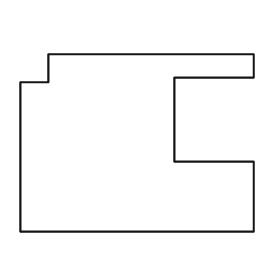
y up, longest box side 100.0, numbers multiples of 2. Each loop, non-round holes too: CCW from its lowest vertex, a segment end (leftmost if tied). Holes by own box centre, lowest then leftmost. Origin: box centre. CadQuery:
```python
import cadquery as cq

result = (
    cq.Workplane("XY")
    .moveTo(-50.0, -38.0)
    .lineTo(50.0, -38.0)
    .lineTo(50.0, -8.0)
    .lineTo(16.0, -8.0)
    .lineTo(16.0, 28.0)
    .lineTo(50.0, 28.0)
    .lineTo(50.0, 38.0)
    .lineTo(-38.0, 38.0)
    .lineTo(-38.0, 26.0)
    .lineTo(-50.0, 26.0)
    .close()
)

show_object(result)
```